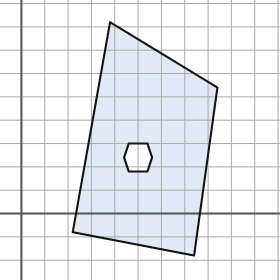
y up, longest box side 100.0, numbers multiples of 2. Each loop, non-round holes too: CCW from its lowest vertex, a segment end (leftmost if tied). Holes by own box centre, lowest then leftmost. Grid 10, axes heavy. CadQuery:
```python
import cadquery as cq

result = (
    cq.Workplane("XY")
    .moveTo(74.0, -18.0)
    .lineTo(84.0, 54.0)
    .lineTo(38.0, 82.0)
    .lineTo(22.0, -8.0)
    .close()
    .moveTo(46.0, 18.0)
    .lineTo(54.0, 18.0)
    .lineTo(56.0, 24.0)
    .lineTo(54.0, 30.0)
    .lineTo(46.0, 30.0)
    .lineTo(44.0, 24.0)
    .close()
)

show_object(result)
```